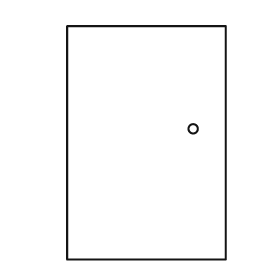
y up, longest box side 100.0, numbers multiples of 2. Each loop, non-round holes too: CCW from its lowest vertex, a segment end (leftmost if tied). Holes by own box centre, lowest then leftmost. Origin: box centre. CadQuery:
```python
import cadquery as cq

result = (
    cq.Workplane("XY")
    .moveTo(-34.0, -50.0)
    .lineTo(34.0, -50.0)
    .lineTo(34.0, 50.0)
    .lineTo(-34.0, 50.0)
    .close()
    .moveTo(20.0, 6.0)
    .circle(2.0)
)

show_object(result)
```